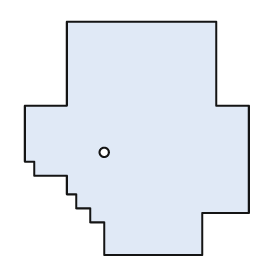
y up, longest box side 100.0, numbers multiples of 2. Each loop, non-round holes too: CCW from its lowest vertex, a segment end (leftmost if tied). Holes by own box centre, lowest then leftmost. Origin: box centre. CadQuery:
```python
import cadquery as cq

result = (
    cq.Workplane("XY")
    .moveTo(-14.0, -50.0)
    .lineTo(28.0, -50.0)
    .lineTo(28.0, -32.0)
    .lineTo(48.0, -32.0)
    .lineTo(48.0, 14.0)
    .lineTo(34.0, 14.0)
    .lineTo(34.0, 50.0)
    .lineTo(-30.0, 50.0)
    .lineTo(-30.0, 14.0)
    .lineTo(-48.0, 14.0)
    .lineTo(-48.0, -10.0)
    .lineTo(-44.0, -10.0)
    .lineTo(-44.0, -16.0)
    .lineTo(-30.0, -16.0)
    .lineTo(-30.0, -24.0)
    .lineTo(-26.0, -24.0)
    .lineTo(-26.0, -30.0)
    .lineTo(-20.0, -30.0)
    .lineTo(-20.0, -36.0)
    .lineTo(-14.0, -36.0)
    .close()
    .moveTo(-14.0, -6.0)
    .circle(2.0)
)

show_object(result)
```